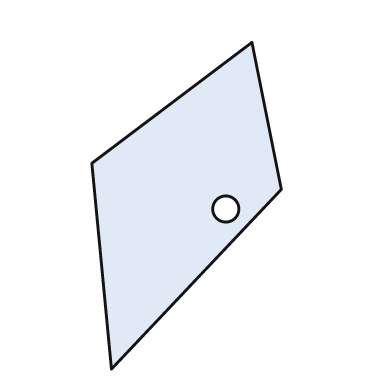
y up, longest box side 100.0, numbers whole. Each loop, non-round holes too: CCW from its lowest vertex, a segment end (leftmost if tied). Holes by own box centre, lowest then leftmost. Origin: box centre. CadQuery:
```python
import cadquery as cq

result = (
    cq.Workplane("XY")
    .moveTo(-23.0, -50.0)
    .lineTo(29.0, 5.0)
    .lineTo(20.0, 50.0)
    .lineTo(-29.0, 13.0)
    .close()
    .moveTo(12.0, -1.0)
    .circle(4.0)
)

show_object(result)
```